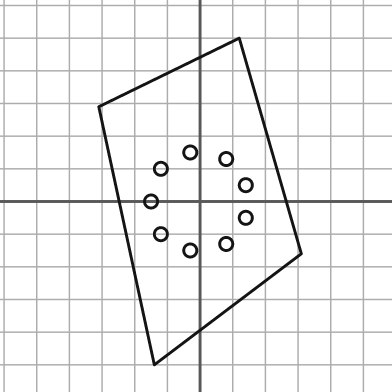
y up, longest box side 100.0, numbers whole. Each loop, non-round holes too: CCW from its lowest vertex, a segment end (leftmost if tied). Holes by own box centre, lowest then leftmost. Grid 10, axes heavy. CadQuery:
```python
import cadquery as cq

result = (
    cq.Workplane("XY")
    .moveTo(-14.0, -50.0)
    .lineTo(31.0, -16.0)
    .lineTo(12.0, 50.0)
    .lineTo(-31.0, 29.0)
    .close()
    .moveTo(-3.0, -15.0)
    .circle(2.0)
    .moveTo(8.0, -13.0)
    .circle(2.0)
    .moveTo(-12.0, -10.0)
    .circle(2.0)
    .moveTo(14.0, -5.0)
    .circle(2.0)
    .moveTo(-15.0, 0.0)
    .circle(2.0)
    .moveTo(14.0, 5.0)
    .circle(2.0)
    .moveTo(-12.0, 10.0)
    .circle(2.0)
    .moveTo(8.0, 13.0)
    .circle(2.0)
    .moveTo(-3.0, 15.0)
    .circle(2.0)
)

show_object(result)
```